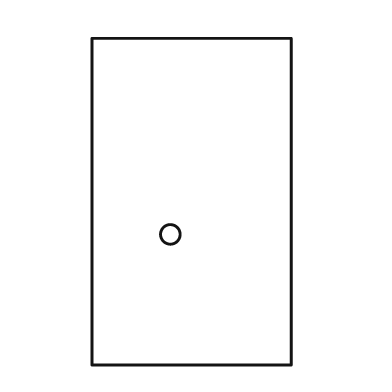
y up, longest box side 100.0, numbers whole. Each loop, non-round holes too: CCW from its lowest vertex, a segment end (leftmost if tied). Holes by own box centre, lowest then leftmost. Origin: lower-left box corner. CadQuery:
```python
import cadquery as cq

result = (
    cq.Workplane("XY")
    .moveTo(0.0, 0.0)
    .lineTo(61.0, 0.0)
    .lineTo(61.0, 100.0)
    .lineTo(0.0, 100.0)
    .close()
    .moveTo(24.0, 40.0)
    .circle(3.0)
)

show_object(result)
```